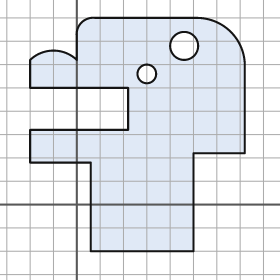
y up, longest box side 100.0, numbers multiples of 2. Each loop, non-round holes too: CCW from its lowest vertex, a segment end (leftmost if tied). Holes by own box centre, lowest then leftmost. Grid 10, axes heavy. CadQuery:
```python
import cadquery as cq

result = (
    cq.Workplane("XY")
    .moveTo(6.0, -20.0)
    .lineTo(50.0, -20.0)
    .lineTo(50.0, 22.0)
    .lineTo(72.0, 22.0)
    .lineTo(72.0, 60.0)
    .threePointArc((66.0, 74.0), (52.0, 80.0))
    .lineTo(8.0, 80.0)
    .threePointArc((2.0, 78.0), (0.0, 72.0))
    .lineTo(0.0, 62.0)
    .threePointArc((-10.0, 66.0), (-20.0, 62.0))
    .lineTo(-20.0, 50.0)
    .lineTo(22.0, 50.0)
    .lineTo(22.0, 32.0)
    .lineTo(-20.0, 32.0)
    .lineTo(-20.0, 18.0)
    .lineTo(6.0, 18.0)
    .close()
    .moveTo(30.0, 56.0)
    .circle(4.0)
    .moveTo(46.0, 68.0)
    .circle(6.0)
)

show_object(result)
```